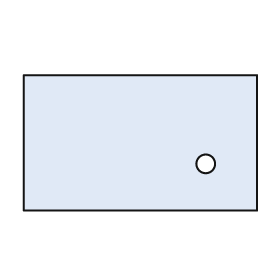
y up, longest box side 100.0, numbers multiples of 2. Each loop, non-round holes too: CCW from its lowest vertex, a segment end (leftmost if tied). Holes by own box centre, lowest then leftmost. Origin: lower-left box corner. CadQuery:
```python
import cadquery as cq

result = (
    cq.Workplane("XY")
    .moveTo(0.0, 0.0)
    .lineTo(100.0, 0.0)
    .lineTo(100.0, 58.0)
    .lineTo(0.0, 58.0)
    .close()
    .moveTo(78.0, 20.0)
    .circle(4.0)
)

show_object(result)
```